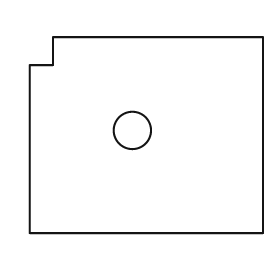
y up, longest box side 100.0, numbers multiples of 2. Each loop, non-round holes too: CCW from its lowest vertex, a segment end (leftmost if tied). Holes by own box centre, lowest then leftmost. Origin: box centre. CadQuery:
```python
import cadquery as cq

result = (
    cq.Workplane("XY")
    .moveTo(-50.0, -42.0)
    .lineTo(50.0, -42.0)
    .lineTo(50.0, 42.0)
    .lineTo(-40.0, 42.0)
    .lineTo(-40.0, 30.0)
    .lineTo(-50.0, 30.0)
    .close()
    .moveTo(-6.0, 2.0)
    .circle(8.0)
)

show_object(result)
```